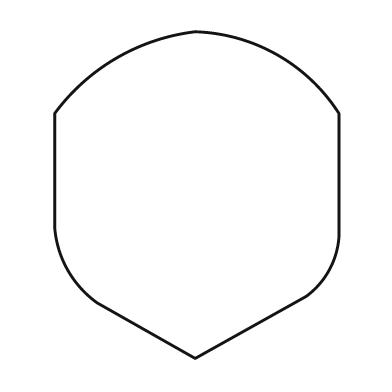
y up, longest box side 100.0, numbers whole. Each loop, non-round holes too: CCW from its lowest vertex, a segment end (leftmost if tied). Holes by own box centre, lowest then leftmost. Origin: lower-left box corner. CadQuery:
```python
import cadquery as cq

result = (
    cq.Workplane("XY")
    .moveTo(43.0, 0.0)
    .lineTo(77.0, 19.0)
    .threePointArc((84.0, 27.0), (87.0, 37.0))
    .lineTo(87.0, 75.0)
    .threePointArc((68.0, 93.0), (43.0, 100.0))
    .threePointArc((19.0, 92.0), (0.0, 75.0))
    .lineTo(0.0, 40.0)
    .threePointArc((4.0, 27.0), (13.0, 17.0))
    .close()
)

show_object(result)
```